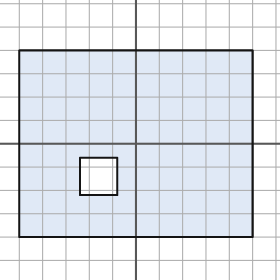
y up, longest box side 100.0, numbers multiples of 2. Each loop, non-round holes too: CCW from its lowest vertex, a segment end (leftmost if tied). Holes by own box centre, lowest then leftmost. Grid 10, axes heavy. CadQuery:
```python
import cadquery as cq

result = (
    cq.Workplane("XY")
    .moveTo(-50.0, -40.0)
    .lineTo(50.0, -40.0)
    .lineTo(50.0, 40.0)
    .lineTo(-50.0, 40.0)
    .close()
    .moveTo(-24.0, -22.0)
    .lineTo(-8.0, -22.0)
    .lineTo(-8.0, -6.0)
    .lineTo(-24.0, -6.0)
    .close()
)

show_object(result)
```